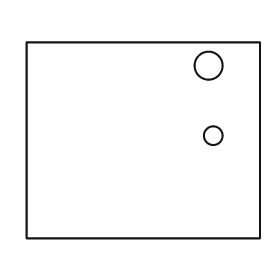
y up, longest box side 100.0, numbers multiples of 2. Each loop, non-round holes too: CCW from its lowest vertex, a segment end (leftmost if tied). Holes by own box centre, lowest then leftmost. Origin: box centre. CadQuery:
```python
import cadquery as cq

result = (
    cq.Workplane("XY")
    .moveTo(-50.0, -42.0)
    .lineTo(50.0, -42.0)
    .lineTo(50.0, 42.0)
    .lineTo(-50.0, 42.0)
    .close()
    .moveTo(30.0, 2.0)
    .circle(4.0)
    .moveTo(28.0, 32.0)
    .circle(6.0)
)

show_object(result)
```